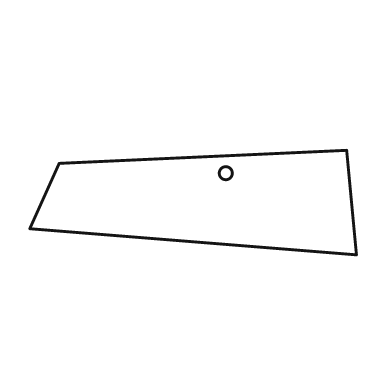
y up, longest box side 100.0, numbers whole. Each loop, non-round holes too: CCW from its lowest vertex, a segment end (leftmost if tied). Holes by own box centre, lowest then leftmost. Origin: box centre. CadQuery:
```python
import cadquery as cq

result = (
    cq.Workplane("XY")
    .moveTo(50.0, -16.0)
    .lineTo(47.0, 16.0)
    .lineTo(-41.0, 12.0)
    .lineTo(-50.0, -8.0)
    .close()
    .moveTo(10.0, 9.0)
    .circle(2.0)
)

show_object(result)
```